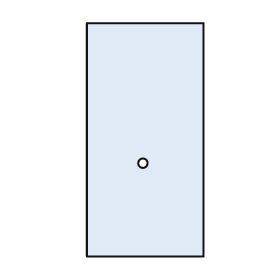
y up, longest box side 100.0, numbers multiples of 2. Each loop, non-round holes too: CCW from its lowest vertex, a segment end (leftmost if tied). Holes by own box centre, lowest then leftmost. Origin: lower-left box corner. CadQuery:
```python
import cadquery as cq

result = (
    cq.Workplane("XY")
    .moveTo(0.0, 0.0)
    .lineTo(50.0, 0.0)
    .lineTo(50.0, 100.0)
    .lineTo(0.0, 100.0)
    .close()
    .moveTo(24.0, 40.0)
    .circle(2.0)
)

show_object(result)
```